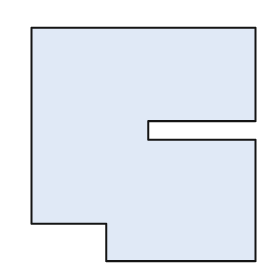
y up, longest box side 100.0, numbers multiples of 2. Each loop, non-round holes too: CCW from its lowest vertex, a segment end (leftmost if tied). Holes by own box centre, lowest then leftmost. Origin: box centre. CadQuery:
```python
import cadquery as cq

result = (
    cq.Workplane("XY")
    .moveTo(-16.0, -50.0)
    .lineTo(48.0, -50.0)
    .lineTo(48.0, 2.0)
    .lineTo(2.0, 2.0)
    .lineTo(2.0, 10.0)
    .lineTo(48.0, 10.0)
    .lineTo(48.0, 50.0)
    .lineTo(-48.0, 50.0)
    .lineTo(-48.0, -34.0)
    .lineTo(-16.0, -34.0)
    .close()
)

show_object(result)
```